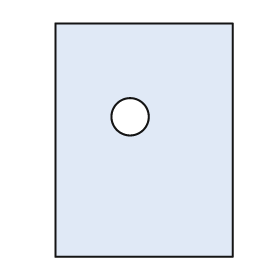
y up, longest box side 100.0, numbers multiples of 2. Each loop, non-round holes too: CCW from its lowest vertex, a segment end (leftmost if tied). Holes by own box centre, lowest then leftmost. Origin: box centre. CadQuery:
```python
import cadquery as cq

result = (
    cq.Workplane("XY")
    .moveTo(-38.0, -50.0)
    .lineTo(38.0, -50.0)
    .lineTo(38.0, 50.0)
    .lineTo(-38.0, 50.0)
    .close()
    .moveTo(-6.0, 10.0)
    .circle(8.0)
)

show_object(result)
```